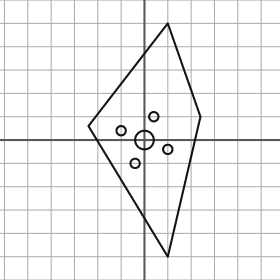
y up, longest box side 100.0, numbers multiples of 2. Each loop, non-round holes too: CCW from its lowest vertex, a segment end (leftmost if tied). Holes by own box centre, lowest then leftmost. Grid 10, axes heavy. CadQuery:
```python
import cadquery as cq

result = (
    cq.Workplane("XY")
    .moveTo(10.0, -50.0)
    .lineTo(24.0, 10.0)
    .lineTo(10.0, 50.0)
    .lineTo(-24.0, 6.0)
    .close()
    .moveTo(-4.0, -10.0)
    .circle(2.0)
    .moveTo(10.0, -4.0)
    .circle(2.0)
    .moveTo(0.0, 0.0)
    .circle(4.0)
    .moveTo(-10.0, 4.0)
    .circle(2.0)
    .moveTo(4.0, 10.0)
    .circle(2.0)
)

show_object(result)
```